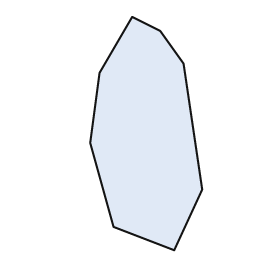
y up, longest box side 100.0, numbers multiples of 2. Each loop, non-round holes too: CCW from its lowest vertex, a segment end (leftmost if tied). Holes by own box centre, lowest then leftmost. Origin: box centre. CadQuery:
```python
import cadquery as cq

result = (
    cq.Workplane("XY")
    .moveTo(12.0, -50.0)
    .lineTo(24.0, -24.0)
    .lineTo(16.0, 30.0)
    .lineTo(6.0, 44.0)
    .lineTo(-6.0, 50.0)
    .lineTo(-20.0, 26.0)
    .lineTo(-24.0, -4.0)
    .lineTo(-14.0, -40.0)
    .close()
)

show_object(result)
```